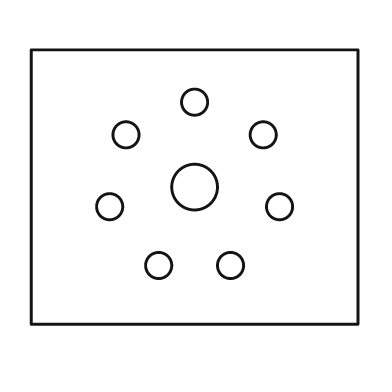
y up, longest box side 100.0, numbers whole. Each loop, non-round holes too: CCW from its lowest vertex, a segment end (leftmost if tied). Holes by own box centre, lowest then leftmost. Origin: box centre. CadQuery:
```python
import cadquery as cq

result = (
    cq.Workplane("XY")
    .moveTo(-50.0, -42.0)
    .lineTo(50.0, -42.0)
    .lineTo(50.0, 42.0)
    .lineTo(-50.0, 42.0)
    .close()
    .moveTo(-11.0, -24.0)
    .circle(4.0)
    .moveTo(11.0, -24.0)
    .circle(4.0)
    .moveTo(-26.0, -6.0)
    .circle(4.0)
    .moveTo(26.0, -6.0)
    .circle(4.0)
    .moveTo(0.0, 0.0)
    .circle(7.0)
    .moveTo(-21.0, 16.0)
    .circle(4.0)
    .moveTo(21.0, 16.0)
    .circle(4.0)
    .moveTo(0.0, 26.0)
    .circle(4.0)
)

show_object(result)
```